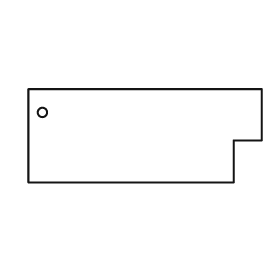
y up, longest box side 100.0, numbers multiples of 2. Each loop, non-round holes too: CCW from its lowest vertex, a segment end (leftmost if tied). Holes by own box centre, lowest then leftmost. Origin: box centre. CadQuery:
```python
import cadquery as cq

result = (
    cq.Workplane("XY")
    .moveTo(-50.0, -20.0)
    .lineTo(38.0, -20.0)
    .lineTo(38.0, -2.0)
    .lineTo(50.0, -2.0)
    .lineTo(50.0, 20.0)
    .lineTo(-50.0, 20.0)
    .close()
    .moveTo(-44.0, 10.0)
    .circle(2.0)
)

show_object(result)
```